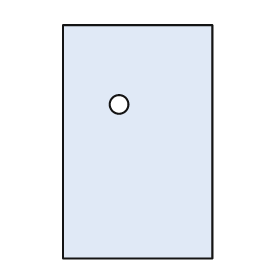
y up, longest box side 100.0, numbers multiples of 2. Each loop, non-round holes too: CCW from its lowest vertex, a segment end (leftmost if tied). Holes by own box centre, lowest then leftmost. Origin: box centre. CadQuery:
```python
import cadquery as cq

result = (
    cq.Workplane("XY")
    .moveTo(-32.0, -50.0)
    .lineTo(32.0, -50.0)
    .lineTo(32.0, 50.0)
    .lineTo(-32.0, 50.0)
    .close()
    .moveTo(-8.0, 16.0)
    .circle(4.0)
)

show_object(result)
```